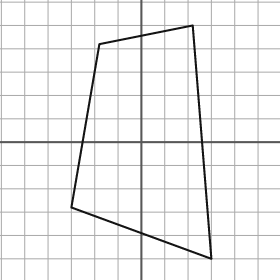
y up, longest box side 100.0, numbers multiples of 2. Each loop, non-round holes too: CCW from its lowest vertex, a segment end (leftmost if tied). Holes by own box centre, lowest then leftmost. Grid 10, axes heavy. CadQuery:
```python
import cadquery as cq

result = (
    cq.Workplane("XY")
    .moveTo(30.0, -50.0)
    .lineTo(22.0, 50.0)
    .lineTo(-18.0, 42.0)
    .lineTo(-30.0, -28.0)
    .close()
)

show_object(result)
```